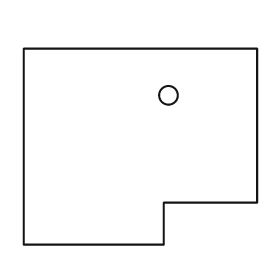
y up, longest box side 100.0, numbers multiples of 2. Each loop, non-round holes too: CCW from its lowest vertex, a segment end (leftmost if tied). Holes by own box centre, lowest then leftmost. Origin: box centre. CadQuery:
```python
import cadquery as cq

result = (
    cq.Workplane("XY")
    .moveTo(-50.0, -42.0)
    .lineTo(10.0, -42.0)
    .lineTo(10.0, -24.0)
    .lineTo(50.0, -24.0)
    .lineTo(50.0, 42.0)
    .lineTo(-50.0, 42.0)
    .close()
    .moveTo(12.0, 22.0)
    .circle(4.0)
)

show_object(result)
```